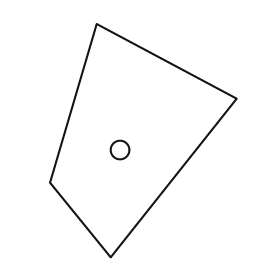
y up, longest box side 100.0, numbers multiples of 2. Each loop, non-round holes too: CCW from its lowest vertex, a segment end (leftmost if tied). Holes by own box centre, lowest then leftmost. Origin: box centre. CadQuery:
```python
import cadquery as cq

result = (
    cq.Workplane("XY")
    .moveTo(-14.0, -50.0)
    .lineTo(40.0, 18.0)
    .lineTo(-20.0, 50.0)
    .lineTo(-40.0, -18.0)
    .close()
    .moveTo(-10.0, -4.0)
    .circle(4.0)
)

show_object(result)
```